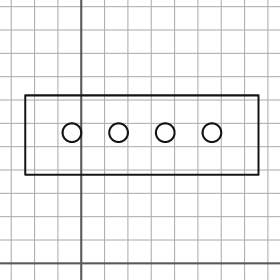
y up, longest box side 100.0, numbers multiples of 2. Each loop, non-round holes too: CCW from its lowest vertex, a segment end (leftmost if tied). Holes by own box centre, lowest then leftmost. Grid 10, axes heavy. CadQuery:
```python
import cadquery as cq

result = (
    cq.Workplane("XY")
    .moveTo(-24.0, 38.0)
    .lineTo(76.0, 38.0)
    .lineTo(76.0, 72.0)
    .lineTo(-24.0, 72.0)
    .close()
    .moveTo(-4.0, 56.0)
    .circle(4.0)
    .moveTo(16.0, 56.0)
    .circle(4.0)
    .moveTo(36.0, 56.0)
    .circle(4.0)
    .moveTo(56.0, 56.0)
    .circle(4.0)
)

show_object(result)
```